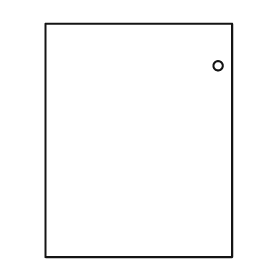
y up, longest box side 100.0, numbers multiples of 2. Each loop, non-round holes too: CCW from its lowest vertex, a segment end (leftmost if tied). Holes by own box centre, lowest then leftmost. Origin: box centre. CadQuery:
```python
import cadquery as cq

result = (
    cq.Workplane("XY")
    .moveTo(-40.0, -50.0)
    .lineTo(40.0, -50.0)
    .lineTo(40.0, 50.0)
    .lineTo(-40.0, 50.0)
    .close()
    .moveTo(34.0, 32.0)
    .circle(2.0)
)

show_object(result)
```